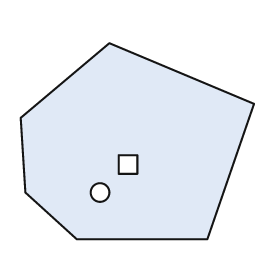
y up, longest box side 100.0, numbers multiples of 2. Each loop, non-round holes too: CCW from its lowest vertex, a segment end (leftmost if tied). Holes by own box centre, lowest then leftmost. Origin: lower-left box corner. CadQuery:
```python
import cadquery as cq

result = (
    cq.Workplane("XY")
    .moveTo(24.0, 0.0)
    .lineTo(80.0, 0.0)
    .lineTo(100.0, 58.0)
    .lineTo(38.0, 84.0)
    .lineTo(0.0, 52.0)
    .lineTo(2.0, 20.0)
    .close()
    .moveTo(34.0, 20.0)
    .circle(4.0)
    .moveTo(42.0, 28.0)
    .lineTo(50.0, 28.0)
    .lineTo(50.0, 36.0)
    .lineTo(42.0, 36.0)
    .close()
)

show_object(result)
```